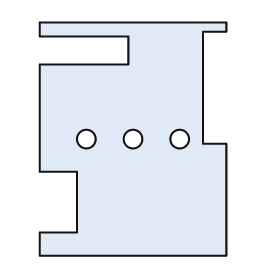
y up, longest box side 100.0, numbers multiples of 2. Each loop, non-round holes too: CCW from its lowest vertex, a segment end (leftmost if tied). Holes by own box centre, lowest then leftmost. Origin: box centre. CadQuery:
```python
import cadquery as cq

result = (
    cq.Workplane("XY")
    .moveTo(-40.0, -50.0)
    .lineTo(40.0, -50.0)
    .lineTo(40.0, -2.0)
    .lineTo(30.0, -2.0)
    .lineTo(30.0, 46.0)
    .lineTo(40.0, 46.0)
    .lineTo(40.0, 50.0)
    .lineTo(-40.0, 50.0)
    .lineTo(-40.0, 44.0)
    .lineTo(-2.0, 44.0)
    .lineTo(-2.0, 32.0)
    .lineTo(-40.0, 32.0)
    .lineTo(-40.0, -14.0)
    .lineTo(-24.0, -14.0)
    .lineTo(-24.0, -40.0)
    .lineTo(-40.0, -40.0)
    .close()
    .moveTo(-20.0, 0.0)
    .circle(4.0)
    .moveTo(0.0, 0.0)
    .circle(4.0)
    .moveTo(20.0, 0.0)
    .circle(4.0)
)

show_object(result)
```